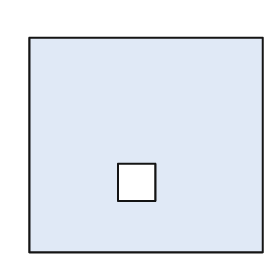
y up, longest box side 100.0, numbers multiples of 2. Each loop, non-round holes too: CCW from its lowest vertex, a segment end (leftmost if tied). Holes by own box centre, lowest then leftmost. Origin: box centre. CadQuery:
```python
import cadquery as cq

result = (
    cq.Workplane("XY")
    .moveTo(-50.0, -46.0)
    .lineTo(50.0, -46.0)
    .lineTo(50.0, 46.0)
    .lineTo(-50.0, 46.0)
    .close()
    .moveTo(-12.0, -24.0)
    .lineTo(4.0, -24.0)
    .lineTo(4.0, -8.0)
    .lineTo(-12.0, -8.0)
    .close()
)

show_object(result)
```